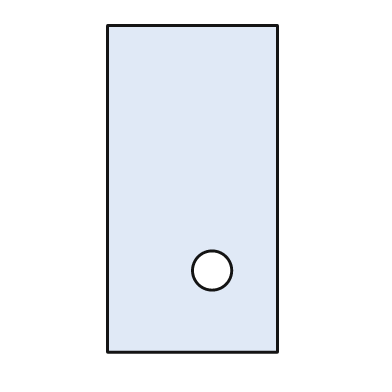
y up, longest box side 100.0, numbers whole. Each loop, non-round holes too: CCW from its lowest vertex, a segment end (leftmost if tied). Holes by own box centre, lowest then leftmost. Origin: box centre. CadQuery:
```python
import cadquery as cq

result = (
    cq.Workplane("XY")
    .moveTo(-26.0, -50.0)
    .lineTo(26.0, -50.0)
    .lineTo(26.0, 50.0)
    .lineTo(-26.0, 50.0)
    .close()
    .moveTo(6.0, -25.0)
    .circle(6.0)
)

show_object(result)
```